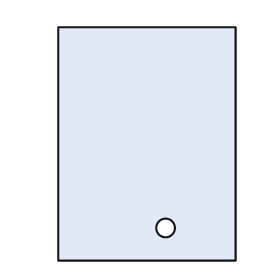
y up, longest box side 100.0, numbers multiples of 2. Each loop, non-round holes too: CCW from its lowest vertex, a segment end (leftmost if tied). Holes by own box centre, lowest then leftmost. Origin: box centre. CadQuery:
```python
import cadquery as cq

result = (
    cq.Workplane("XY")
    .moveTo(-38.0, -50.0)
    .lineTo(38.0, -50.0)
    .lineTo(38.0, 50.0)
    .lineTo(-38.0, 50.0)
    .close()
    .moveTo(8.0, -36.0)
    .circle(4.0)
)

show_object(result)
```